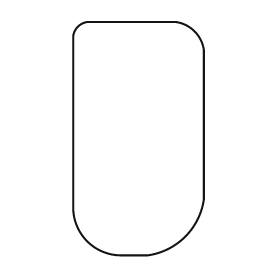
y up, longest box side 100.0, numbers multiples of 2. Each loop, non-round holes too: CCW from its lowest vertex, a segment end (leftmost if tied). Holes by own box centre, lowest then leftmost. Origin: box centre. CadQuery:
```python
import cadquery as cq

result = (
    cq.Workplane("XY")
    .moveTo(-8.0, -50.0)
    .lineTo(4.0, -50.0)
    .threePointArc((20.0, -42.0), (28.0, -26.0))
    .lineTo(28.0, 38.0)
    .threePointArc((24.0, 46.0), (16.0, 50.0))
    .lineTo(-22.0, 50.0)
    .threePointArc((-26.0, 48.0), (-28.0, 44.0))
    .lineTo(-28.0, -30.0)
    .threePointArc((-22.0, -44.0), (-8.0, -50.0))
    .close()
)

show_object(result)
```